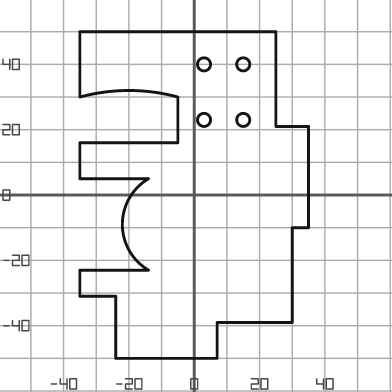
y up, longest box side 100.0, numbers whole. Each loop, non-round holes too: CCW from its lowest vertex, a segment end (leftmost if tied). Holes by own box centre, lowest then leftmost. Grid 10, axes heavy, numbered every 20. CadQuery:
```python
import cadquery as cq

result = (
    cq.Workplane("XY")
    .moveTo(-24.0, -50.0)
    .lineTo(7.0, -50.0)
    .lineTo(7.0, -39.0)
    .lineTo(30.0, -39.0)
    .lineTo(30.0, -10.0)
    .lineTo(35.0, -10.0)
    .lineTo(35.0, 21.0)
    .lineTo(25.0, 21.0)
    .lineTo(25.0, 50.0)
    .lineTo(-35.0, 50.0)
    .lineTo(-35.0, 30.0)
    .threePointArc((-20.0, 32.0), (-5.0, 30.0))
    .lineTo(-5.0, 16.0)
    .lineTo(-35.0, 16.0)
    .lineTo(-35.0, 5.0)
    .lineTo(-14.0, 5.0)
    .threePointArc((-22.0, -9.0), (-14.0, -23.0))
    .lineTo(-35.0, -23.0)
    .lineTo(-35.0, -31.0)
    .lineTo(-24.0, -31.0)
    .close()
    .moveTo(3.0, 23.0)
    .circle(2.0)
    .moveTo(15.0, 23.0)
    .circle(2.0)
    .moveTo(3.0, 40.0)
    .circle(2.0)
    .moveTo(15.0, 40.0)
    .circle(2.0)
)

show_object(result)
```